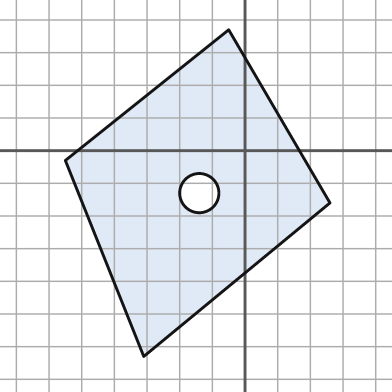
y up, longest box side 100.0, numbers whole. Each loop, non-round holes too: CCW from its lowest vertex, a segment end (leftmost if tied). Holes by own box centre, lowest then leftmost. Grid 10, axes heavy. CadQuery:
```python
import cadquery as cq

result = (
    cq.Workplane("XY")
    .moveTo(-31.0, -63.0)
    .lineTo(26.0, -16.0)
    .lineTo(-5.0, 37.0)
    .lineTo(-55.0, -3.0)
    .close()
    .moveTo(-14.0, -13.0)
    .circle(6.0)
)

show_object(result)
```